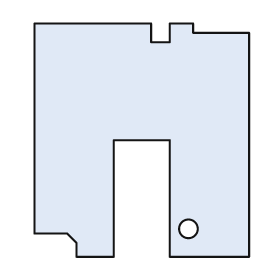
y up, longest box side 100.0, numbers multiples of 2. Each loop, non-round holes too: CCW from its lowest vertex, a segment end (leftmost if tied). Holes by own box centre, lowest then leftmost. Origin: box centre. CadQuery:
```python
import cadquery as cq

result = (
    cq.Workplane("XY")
    .moveTo(-28.0, -50.0)
    .lineTo(-12.0, -50.0)
    .lineTo(-12.0, 0.0)
    .lineTo(12.0, 0.0)
    .lineTo(12.0, -50.0)
    .lineTo(46.0, -50.0)
    .lineTo(46.0, 46.0)
    .lineTo(22.0, 46.0)
    .lineTo(22.0, 50.0)
    .lineTo(12.0, 50.0)
    .lineTo(12.0, 42.0)
    .lineTo(4.0, 42.0)
    .lineTo(4.0, 50.0)
    .lineTo(-46.0, 50.0)
    .lineTo(-46.0, -40.0)
    .lineTo(-32.0, -40.0)
    .lineTo(-28.0, -44.0)
    .close()
    .moveTo(20.0, -38.0)
    .circle(4.0)
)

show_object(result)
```